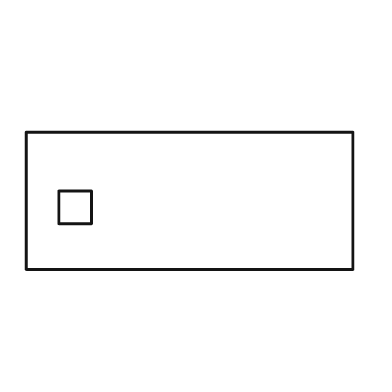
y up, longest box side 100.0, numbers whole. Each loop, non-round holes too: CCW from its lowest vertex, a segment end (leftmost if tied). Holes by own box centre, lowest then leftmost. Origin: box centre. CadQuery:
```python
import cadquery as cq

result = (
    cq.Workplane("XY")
    .moveTo(-50.0, -21.0)
    .lineTo(50.0, -21.0)
    .lineTo(50.0, 21.0)
    .lineTo(-50.0, 21.0)
    .close()
    .moveTo(-40.0, -7.0)
    .lineTo(-30.0, -7.0)
    .lineTo(-30.0, 3.0)
    .lineTo(-40.0, 3.0)
    .close()
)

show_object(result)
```